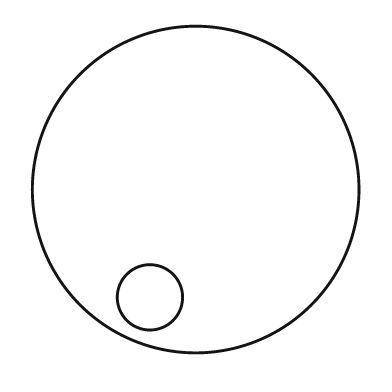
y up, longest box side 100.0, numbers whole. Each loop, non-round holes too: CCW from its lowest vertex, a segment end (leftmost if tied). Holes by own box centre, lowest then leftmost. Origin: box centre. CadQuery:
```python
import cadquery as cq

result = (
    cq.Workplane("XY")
    .moveTo(0.0, 0.0)
    .circle(50.0)
    .moveTo(-14.0, -33.0)
    .circle(10.0)
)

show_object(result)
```